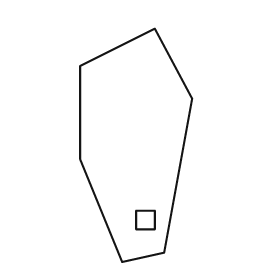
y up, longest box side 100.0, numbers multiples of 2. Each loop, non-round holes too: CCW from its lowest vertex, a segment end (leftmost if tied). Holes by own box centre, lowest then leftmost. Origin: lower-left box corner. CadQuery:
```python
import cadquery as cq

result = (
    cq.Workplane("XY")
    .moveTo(18.0, 0.0)
    .lineTo(36.0, 4.0)
    .lineTo(48.0, 70.0)
    .lineTo(32.0, 100.0)
    .lineTo(0.0, 84.0)
    .lineTo(0.0, 44.0)
    .close()
    .moveTo(24.0, 14.0)
    .lineTo(32.0, 14.0)
    .lineTo(32.0, 22.0)
    .lineTo(24.0, 22.0)
    .close()
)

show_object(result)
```